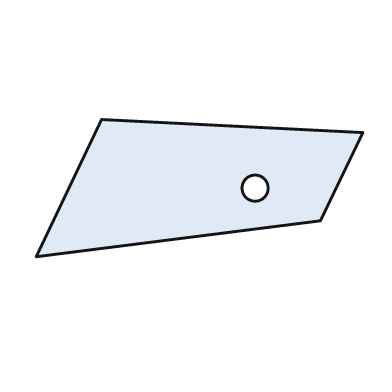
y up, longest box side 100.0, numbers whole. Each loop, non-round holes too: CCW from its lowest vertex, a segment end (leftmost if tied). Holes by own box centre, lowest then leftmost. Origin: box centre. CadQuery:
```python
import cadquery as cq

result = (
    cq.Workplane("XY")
    .moveTo(-50.0, -21.0)
    .lineTo(37.0, -10.0)
    .lineTo(50.0, 17.0)
    .lineTo(-30.0, 21.0)
    .close()
    .moveTo(17.0, 0.0)
    .circle(4.0)
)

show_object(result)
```